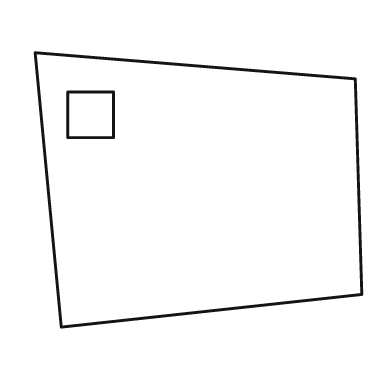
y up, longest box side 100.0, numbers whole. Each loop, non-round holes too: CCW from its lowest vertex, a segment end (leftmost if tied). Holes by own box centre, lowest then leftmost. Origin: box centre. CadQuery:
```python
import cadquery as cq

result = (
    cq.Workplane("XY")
    .moveTo(-42.0, -42.0)
    .lineTo(50.0, -32.0)
    .lineTo(48.0, 34.0)
    .lineTo(-50.0, 42.0)
    .close()
    .moveTo(-40.0, 16.0)
    .lineTo(-26.0, 16.0)
    .lineTo(-26.0, 30.0)
    .lineTo(-40.0, 30.0)
    .close()
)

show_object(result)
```